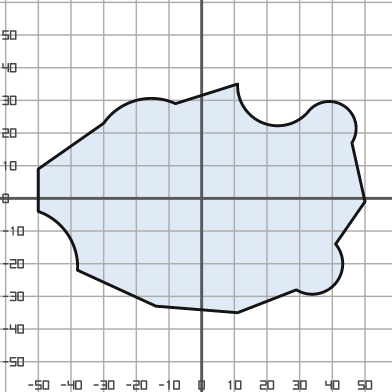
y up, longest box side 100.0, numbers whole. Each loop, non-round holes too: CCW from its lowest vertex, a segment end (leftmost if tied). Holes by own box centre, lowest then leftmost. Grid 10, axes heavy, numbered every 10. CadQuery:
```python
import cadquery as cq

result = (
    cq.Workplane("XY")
    .moveTo(11.0, -35.0)
    .lineTo(29.0, -28.0)
    .threePointArc((41.0, -26.0), (41.0, -14.0))
    .lineTo(50.0, -1.0)
    .lineTo(46.0, 17.0)
    .threePointArc((44.0, 28.0), (33.0, 27.0))
    .threePointArc((19.0, 23.0), (11.0, 35.0))
    .lineTo(-8.0, 29.0)
    .threePointArc((-20.0, 30.0), (-30.0, 23.0))
    .lineTo(-50.0, 9.0)
    .lineTo(-50.0, -4.0)
    .threePointArc((-41.0, -11.0), (-38.0, -22.0))
    .lineTo(-14.0, -33.0)
    .close()
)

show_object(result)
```